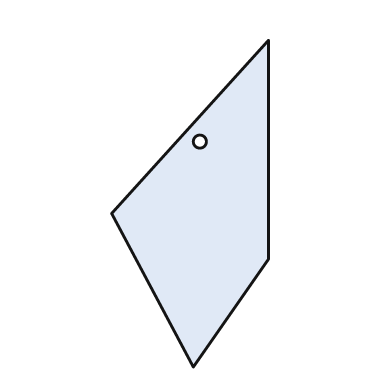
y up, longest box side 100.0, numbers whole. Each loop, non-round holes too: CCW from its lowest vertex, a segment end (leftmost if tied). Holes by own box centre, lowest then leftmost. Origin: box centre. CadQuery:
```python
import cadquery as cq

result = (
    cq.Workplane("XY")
    .moveTo(1.0, -50.0)
    .lineTo(24.0, -17.0)
    .lineTo(24.0, 50.0)
    .lineTo(-24.0, -3.0)
    .close()
    .moveTo(3.0, 19.0)
    .circle(2.0)
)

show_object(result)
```